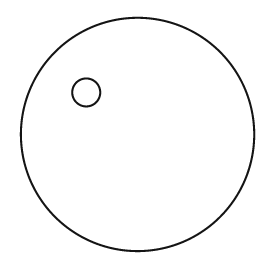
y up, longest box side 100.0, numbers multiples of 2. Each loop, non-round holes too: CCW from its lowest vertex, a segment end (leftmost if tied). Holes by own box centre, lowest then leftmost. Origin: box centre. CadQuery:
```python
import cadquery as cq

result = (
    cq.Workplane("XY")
    .moveTo(0.0, 0.0)
    .circle(50.0)
    .moveTo(-22.0, 18.0)
    .circle(6.0)
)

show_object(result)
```